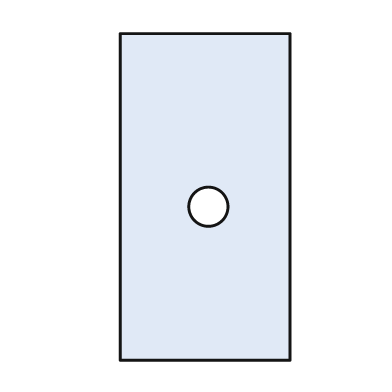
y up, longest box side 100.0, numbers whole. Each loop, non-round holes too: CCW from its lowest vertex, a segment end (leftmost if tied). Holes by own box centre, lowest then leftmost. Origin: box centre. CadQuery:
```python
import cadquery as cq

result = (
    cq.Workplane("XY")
    .moveTo(-26.0, -50.0)
    .lineTo(26.0, -50.0)
    .lineTo(26.0, 50.0)
    .lineTo(-26.0, 50.0)
    .close()
    .moveTo(1.0, -3.0)
    .circle(6.0)
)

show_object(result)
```